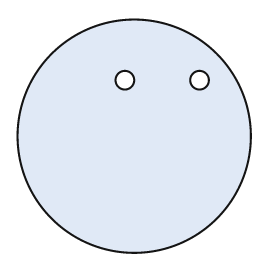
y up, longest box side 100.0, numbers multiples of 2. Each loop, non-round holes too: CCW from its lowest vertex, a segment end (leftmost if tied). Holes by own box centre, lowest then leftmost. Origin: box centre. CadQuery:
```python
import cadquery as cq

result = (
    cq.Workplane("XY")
    .moveTo(0.0, 0.0)
    .circle(50.0)
    .moveTo(-4.0, 24.0)
    .circle(4.0)
    .moveTo(28.0, 24.0)
    .circle(4.0)
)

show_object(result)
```